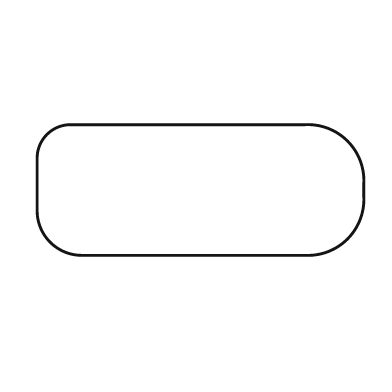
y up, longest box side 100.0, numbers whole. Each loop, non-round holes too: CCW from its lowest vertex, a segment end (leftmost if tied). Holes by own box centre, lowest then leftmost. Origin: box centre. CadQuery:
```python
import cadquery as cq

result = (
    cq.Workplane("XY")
    .moveTo(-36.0, -20.0)
    .lineTo(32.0, -20.0)
    .threePointArc((45.0, -15.0), (50.0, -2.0))
    .lineTo(50.0, 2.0)
    .threePointArc((45.0, 15.0), (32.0, 20.0))
    .lineTo(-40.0, 20.0)
    .threePointArc((-47.0, 17.0), (-50.0, 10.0))
    .lineTo(-50.0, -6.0)
    .threePointArc((-46.0, -16.0), (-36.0, -20.0))
    .close()
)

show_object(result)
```